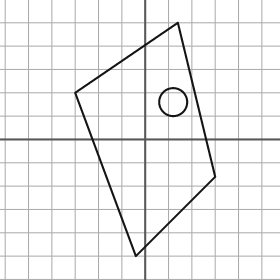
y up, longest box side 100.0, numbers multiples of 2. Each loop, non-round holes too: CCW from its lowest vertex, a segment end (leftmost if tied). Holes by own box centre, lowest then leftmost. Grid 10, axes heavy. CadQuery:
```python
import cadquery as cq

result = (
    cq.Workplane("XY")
    .moveTo(-4.0, -50.0)
    .lineTo(30.0, -16.0)
    .lineTo(14.0, 50.0)
    .lineTo(-30.0, 20.0)
    .close()
    .moveTo(12.0, 16.0)
    .circle(6.0)
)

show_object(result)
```